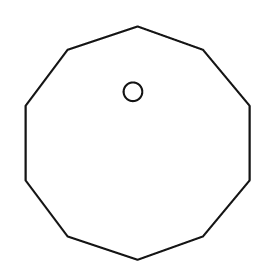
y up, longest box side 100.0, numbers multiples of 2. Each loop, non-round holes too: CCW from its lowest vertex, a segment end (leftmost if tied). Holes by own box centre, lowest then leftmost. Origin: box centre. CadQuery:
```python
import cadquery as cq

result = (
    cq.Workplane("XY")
    .moveTo(0.0, -50.0)
    .lineTo(28.0, -40.0)
    .lineTo(48.0, -16.0)
    .lineTo(48.0, 16.0)
    .lineTo(28.0, 40.0)
    .lineTo(0.0, 50.0)
    .lineTo(-30.0, 40.0)
    .lineTo(-48.0, 16.0)
    .lineTo(-48.0, -16.0)
    .lineTo(-30.0, -40.0)
    .close()
    .moveTo(-2.0, 22.0)
    .circle(4.0)
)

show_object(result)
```